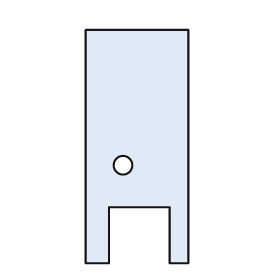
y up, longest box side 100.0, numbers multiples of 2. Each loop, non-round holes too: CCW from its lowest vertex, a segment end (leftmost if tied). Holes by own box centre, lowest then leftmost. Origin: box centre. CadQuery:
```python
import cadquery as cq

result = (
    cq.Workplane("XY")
    .moveTo(-22.0, -50.0)
    .lineTo(-12.0, -50.0)
    .lineTo(-12.0, -26.0)
    .lineTo(14.0, -26.0)
    .lineTo(14.0, -50.0)
    .lineTo(22.0, -50.0)
    .lineTo(22.0, 50.0)
    .lineTo(-22.0, 50.0)
    .close()
    .moveTo(-6.0, -8.0)
    .circle(4.0)
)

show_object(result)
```